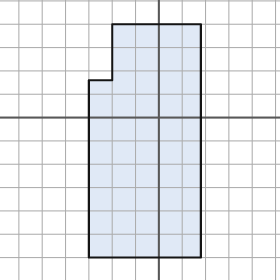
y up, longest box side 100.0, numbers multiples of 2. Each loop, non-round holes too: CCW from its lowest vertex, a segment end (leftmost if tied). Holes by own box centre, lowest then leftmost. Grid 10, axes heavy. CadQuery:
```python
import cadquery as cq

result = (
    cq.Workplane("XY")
    .moveTo(-30.0, -60.0)
    .lineTo(18.0, -60.0)
    .lineTo(18.0, 40.0)
    .lineTo(-20.0, 40.0)
    .lineTo(-20.0, 16.0)
    .lineTo(-30.0, 16.0)
    .close()
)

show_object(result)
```